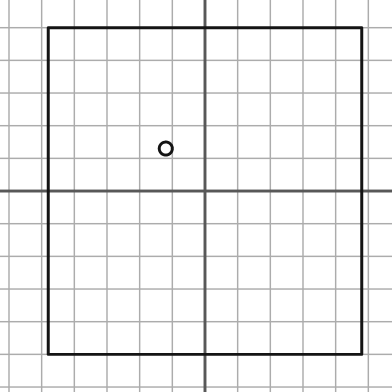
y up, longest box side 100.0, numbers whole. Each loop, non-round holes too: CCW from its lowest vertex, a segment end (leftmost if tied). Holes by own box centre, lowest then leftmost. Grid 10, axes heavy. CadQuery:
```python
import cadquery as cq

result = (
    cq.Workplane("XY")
    .moveTo(-48.0, -50.0)
    .lineTo(48.0, -50.0)
    .lineTo(48.0, 50.0)
    .lineTo(-48.0, 50.0)
    .close()
    .moveTo(-12.0, 13.0)
    .circle(2.0)
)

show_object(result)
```